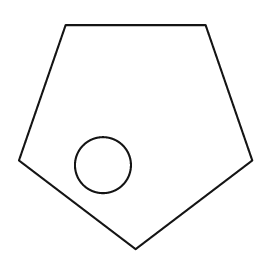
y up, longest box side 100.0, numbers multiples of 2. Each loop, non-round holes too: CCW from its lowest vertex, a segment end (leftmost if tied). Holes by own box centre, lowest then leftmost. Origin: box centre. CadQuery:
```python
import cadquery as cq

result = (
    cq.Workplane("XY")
    .moveTo(0.0, -48.0)
    .lineTo(50.0, -10.0)
    .lineTo(30.0, 48.0)
    .lineTo(-30.0, 48.0)
    .lineTo(-50.0, -10.0)
    .close()
    .moveTo(-14.0, -12.0)
    .circle(12.0)
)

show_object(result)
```